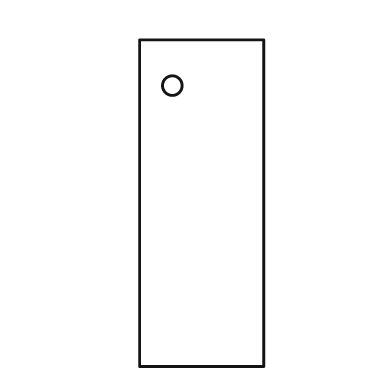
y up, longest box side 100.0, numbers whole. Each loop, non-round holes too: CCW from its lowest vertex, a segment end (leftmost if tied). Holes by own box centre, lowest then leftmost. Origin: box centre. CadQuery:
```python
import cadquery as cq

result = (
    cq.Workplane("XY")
    .moveTo(-19.0, -50.0)
    .lineTo(19.0, -50.0)
    .lineTo(19.0, 50.0)
    .lineTo(-19.0, 50.0)
    .close()
    .moveTo(-9.0, 36.0)
    .circle(3.0)
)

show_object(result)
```